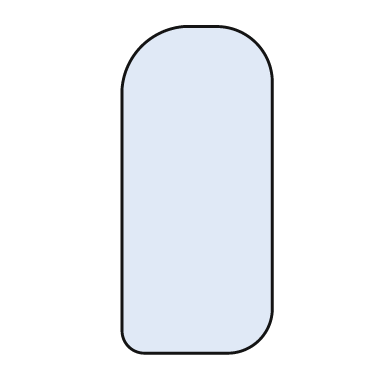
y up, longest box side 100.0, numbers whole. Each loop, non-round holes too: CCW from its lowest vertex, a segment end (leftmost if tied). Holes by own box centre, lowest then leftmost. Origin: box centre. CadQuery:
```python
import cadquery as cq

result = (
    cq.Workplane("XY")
    .moveTo(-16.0, -50.0)
    .lineTo(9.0, -50.0)
    .threePointArc((19.0, -46.0), (23.0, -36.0))
    .lineTo(23.0, 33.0)
    .threePointArc((18.0, 45.0), (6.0, 50.0))
    .lineTo(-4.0, 50.0)
    .threePointArc((-17.0, 44.0), (-23.0, 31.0))
    .lineTo(-23.0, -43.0)
    .threePointArc((-21.0, -48.0), (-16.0, -50.0))
    .close()
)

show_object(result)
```